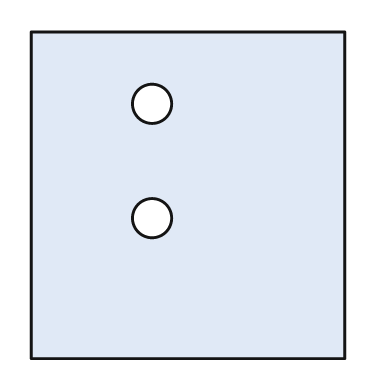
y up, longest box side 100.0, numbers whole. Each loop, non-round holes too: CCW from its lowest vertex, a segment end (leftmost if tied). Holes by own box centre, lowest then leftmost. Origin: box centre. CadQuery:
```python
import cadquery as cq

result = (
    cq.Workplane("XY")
    .moveTo(-48.0, -50.0)
    .lineTo(48.0, -50.0)
    .lineTo(48.0, 50.0)
    .lineTo(-48.0, 50.0)
    .close()
    .moveTo(-11.0, -7.0)
    .circle(6.0)
    .moveTo(-11.0, 28.0)
    .circle(6.0)
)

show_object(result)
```